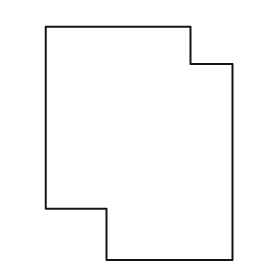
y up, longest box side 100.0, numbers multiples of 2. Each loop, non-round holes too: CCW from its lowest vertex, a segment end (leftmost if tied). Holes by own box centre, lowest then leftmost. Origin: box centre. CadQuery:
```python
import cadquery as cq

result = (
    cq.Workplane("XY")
    .moveTo(-14.0, -50.0)
    .lineTo(40.0, -50.0)
    .lineTo(40.0, 34.0)
    .lineTo(22.0, 34.0)
    .lineTo(22.0, 50.0)
    .lineTo(-40.0, 50.0)
    .lineTo(-40.0, -28.0)
    .lineTo(-14.0, -28.0)
    .close()
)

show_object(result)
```